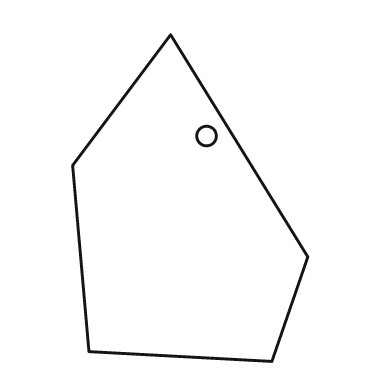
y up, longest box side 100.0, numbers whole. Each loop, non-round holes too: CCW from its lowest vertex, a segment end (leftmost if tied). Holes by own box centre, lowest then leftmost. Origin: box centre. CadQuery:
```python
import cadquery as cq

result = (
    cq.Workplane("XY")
    .moveTo(25.0, -50.0)
    .lineTo(36.0, -18.0)
    .lineTo(-6.0, 50.0)
    .lineTo(-36.0, 10.0)
    .lineTo(-31.0, -47.0)
    .close()
    .moveTo(5.0, 19.0)
    .circle(3.0)
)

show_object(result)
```